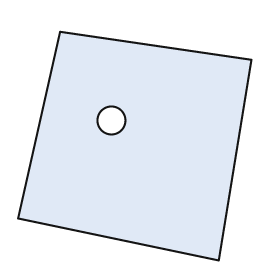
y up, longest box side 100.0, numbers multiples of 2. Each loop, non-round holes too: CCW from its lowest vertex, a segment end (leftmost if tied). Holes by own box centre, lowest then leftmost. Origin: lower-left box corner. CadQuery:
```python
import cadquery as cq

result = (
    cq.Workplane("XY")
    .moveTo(86.0, 0.0)
    .lineTo(100.0, 86.0)
    .lineTo(18.0, 98.0)
    .lineTo(0.0, 18.0)
    .close()
    .moveTo(40.0, 60.0)
    .circle(6.0)
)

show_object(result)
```